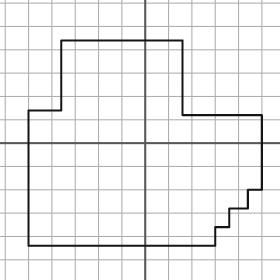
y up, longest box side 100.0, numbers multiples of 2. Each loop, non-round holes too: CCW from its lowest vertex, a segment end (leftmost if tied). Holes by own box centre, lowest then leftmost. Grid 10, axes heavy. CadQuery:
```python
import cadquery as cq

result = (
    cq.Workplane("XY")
    .moveTo(-50.0, -44.0)
    .lineTo(30.0, -44.0)
    .lineTo(30.0, -36.0)
    .lineTo(36.0, -36.0)
    .lineTo(36.0, -28.0)
    .lineTo(44.0, -28.0)
    .lineTo(44.0, -20.0)
    .lineTo(50.0, -20.0)
    .lineTo(50.0, 12.0)
    .lineTo(16.0, 12.0)
    .lineTo(16.0, 44.0)
    .lineTo(-36.0, 44.0)
    .lineTo(-36.0, 14.0)
    .lineTo(-50.0, 14.0)
    .close()
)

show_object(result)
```